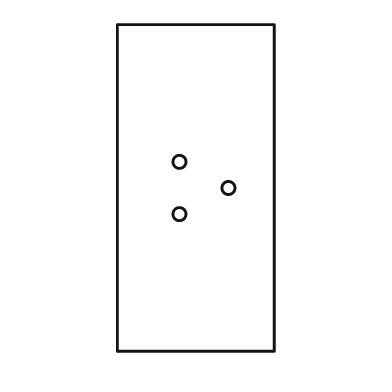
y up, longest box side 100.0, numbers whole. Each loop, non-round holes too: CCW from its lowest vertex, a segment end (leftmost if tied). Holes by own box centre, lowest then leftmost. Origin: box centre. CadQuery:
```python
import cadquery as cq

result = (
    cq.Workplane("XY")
    .moveTo(-24.0, -50.0)
    .lineTo(24.0, -50.0)
    .lineTo(24.0, 50.0)
    .lineTo(-24.0, 50.0)
    .close()
    .moveTo(-5.0, -8.0)
    .circle(2.0)
    .moveTo(10.0, 0.0)
    .circle(2.0)
    .moveTo(-5.0, 8.0)
    .circle(2.0)
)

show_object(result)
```